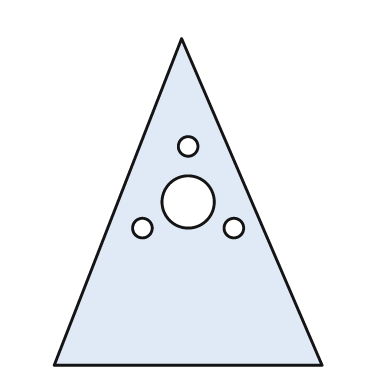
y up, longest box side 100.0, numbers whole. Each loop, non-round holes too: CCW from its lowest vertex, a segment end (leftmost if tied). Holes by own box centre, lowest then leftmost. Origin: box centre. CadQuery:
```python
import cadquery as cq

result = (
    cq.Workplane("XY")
    .moveTo(-41.0, -50.0)
    .lineTo(41.0, -50.0)
    .lineTo(-2.0, 50.0)
    .close()
    .moveTo(-14.0, -8.0)
    .circle(3.0)
    .moveTo(14.0, -8.0)
    .circle(3.0)
    .moveTo(0.0, 0.0)
    .circle(8.0)
    .moveTo(0.0, 17.0)
    .circle(3.0)
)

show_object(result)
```